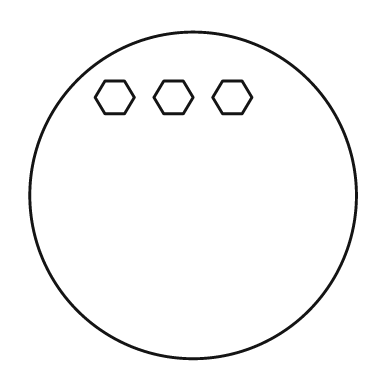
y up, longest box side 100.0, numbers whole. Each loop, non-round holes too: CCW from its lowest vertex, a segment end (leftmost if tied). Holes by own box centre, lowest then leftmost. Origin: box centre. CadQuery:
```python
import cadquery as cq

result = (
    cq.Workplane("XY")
    .moveTo(0.0, 0.0)
    .circle(50.0)
    .moveTo(-27.0, 25.0)
    .lineTo(-21.0, 25.0)
    .lineTo(-18.0, 30.0)
    .lineTo(-21.0, 35.0)
    .lineTo(-27.0, 35.0)
    .lineTo(-30.0, 30.0)
    .close()
    .moveTo(-9.0, 25.0)
    .lineTo(-3.0, 25.0)
    .lineTo(0.0, 30.0)
    .lineTo(-3.0, 35.0)
    .lineTo(-9.0, 35.0)
    .lineTo(-12.0, 30.0)
    .close()
    .moveTo(9.0, 25.0)
    .lineTo(15.0, 25.0)
    .lineTo(18.0, 30.0)
    .lineTo(15.0, 35.0)
    .lineTo(9.0, 35.0)
    .lineTo(6.0, 30.0)
    .close()
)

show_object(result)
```